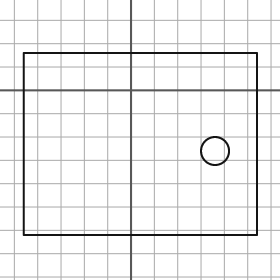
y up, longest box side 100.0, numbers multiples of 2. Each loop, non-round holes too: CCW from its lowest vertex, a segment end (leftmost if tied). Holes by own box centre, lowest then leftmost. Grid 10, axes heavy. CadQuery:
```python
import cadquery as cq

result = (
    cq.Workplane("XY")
    .moveTo(-46.0, -62.0)
    .lineTo(54.0, -62.0)
    .lineTo(54.0, 16.0)
    .lineTo(-46.0, 16.0)
    .close()
    .moveTo(36.0, -26.0)
    .circle(6.0)
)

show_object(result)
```